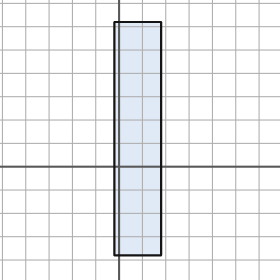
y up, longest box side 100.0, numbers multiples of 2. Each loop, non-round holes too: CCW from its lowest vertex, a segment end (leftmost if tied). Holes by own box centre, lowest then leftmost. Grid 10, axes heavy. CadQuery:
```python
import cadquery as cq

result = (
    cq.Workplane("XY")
    .moveTo(-2.0, -38.0)
    .lineTo(18.0, -38.0)
    .lineTo(18.0, 62.0)
    .lineTo(-2.0, 62.0)
    .close()
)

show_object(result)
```